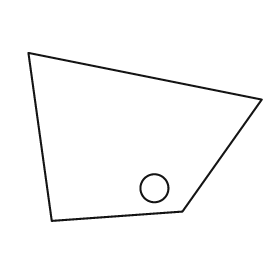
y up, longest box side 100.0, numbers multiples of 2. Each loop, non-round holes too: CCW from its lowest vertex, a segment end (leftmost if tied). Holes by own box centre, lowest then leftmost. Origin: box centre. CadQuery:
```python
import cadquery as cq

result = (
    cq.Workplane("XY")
    .moveTo(-40.0, -36.0)
    .lineTo(16.0, -32.0)
    .lineTo(50.0, 16.0)
    .lineTo(-50.0, 36.0)
    .close()
    .moveTo(4.0, -22.0)
    .circle(6.0)
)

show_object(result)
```